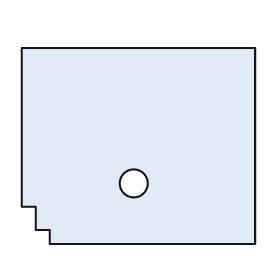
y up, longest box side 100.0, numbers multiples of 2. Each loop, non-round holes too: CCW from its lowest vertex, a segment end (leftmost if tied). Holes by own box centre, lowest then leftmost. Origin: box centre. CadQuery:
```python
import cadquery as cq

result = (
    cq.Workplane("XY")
    .moveTo(-38.0, -42.0)
    .lineTo(50.0, -42.0)
    .lineTo(50.0, 42.0)
    .lineTo(-50.0, 42.0)
    .lineTo(-50.0, -26.0)
    .lineTo(-44.0, -26.0)
    .lineTo(-44.0, -36.0)
    .lineTo(-38.0, -36.0)
    .close()
    .moveTo(-2.0, -16.0)
    .circle(6.0)
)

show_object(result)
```